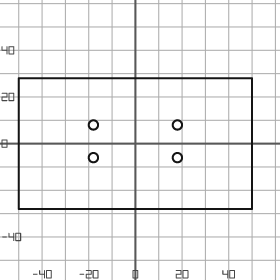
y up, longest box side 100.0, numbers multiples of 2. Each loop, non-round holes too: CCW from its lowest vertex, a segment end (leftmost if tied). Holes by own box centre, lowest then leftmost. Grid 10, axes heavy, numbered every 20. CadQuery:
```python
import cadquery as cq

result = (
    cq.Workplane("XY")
    .moveTo(-50.0, -28.0)
    .lineTo(50.0, -28.0)
    .lineTo(50.0, 28.0)
    .lineTo(-50.0, 28.0)
    .close()
    .moveTo(-18.0, -6.0)
    .circle(2.0)
    .moveTo(18.0, -6.0)
    .circle(2.0)
    .moveTo(-18.0, 8.0)
    .circle(2.0)
    .moveTo(18.0, 8.0)
    .circle(2.0)
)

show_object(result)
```